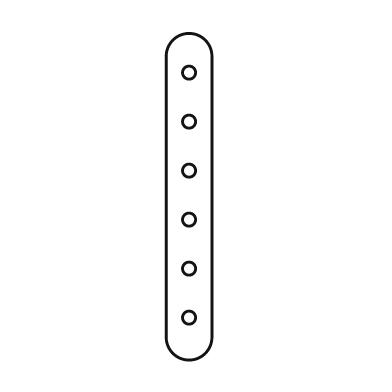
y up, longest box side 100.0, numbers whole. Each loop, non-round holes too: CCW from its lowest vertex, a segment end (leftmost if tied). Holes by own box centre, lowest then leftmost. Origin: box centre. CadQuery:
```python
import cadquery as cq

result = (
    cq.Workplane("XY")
    .moveTo(-7.0, -43.0)
    .threePointArc((0.0, -50.0), (7.0, -43.0))
    .lineTo(7.0, 43.0)
    .threePointArc((0.0, 50.0), (-7.0, 43.0))
    .close()
    .moveTo(0.0, -37.0)
    .circle(2.0)
    .moveTo(0.0, -22.0)
    .circle(2.0)
    .moveTo(0.0, -7.0)
    .circle(2.0)
    .moveTo(0.0, 8.0)
    .circle(2.0)
    .moveTo(0.0, 23.0)
    .circle(2.0)
    .moveTo(0.0, 38.0)
    .circle(2.0)
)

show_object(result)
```